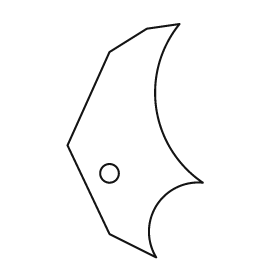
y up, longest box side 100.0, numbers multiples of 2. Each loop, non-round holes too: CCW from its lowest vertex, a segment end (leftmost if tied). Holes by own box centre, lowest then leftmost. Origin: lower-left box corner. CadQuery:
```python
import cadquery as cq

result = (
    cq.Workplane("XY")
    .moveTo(38.0, 0.0)
    .threePointArc((38.0, 22.0), (58.0, 32.0))
    .threePointArc((38.0, 64.0), (48.0, 100.0))
    .lineTo(34.0, 98.0)
    .lineTo(18.0, 88.0)
    .lineTo(0.0, 48.0)
    .lineTo(18.0, 10.0)
    .close()
    .moveTo(18.0, 36.0)
    .circle(4.0)
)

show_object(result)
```